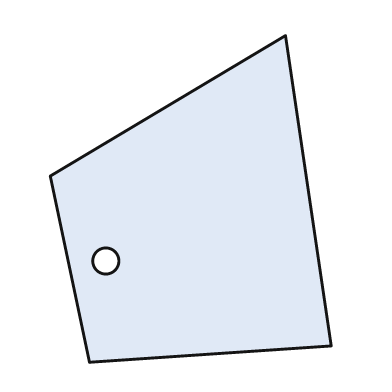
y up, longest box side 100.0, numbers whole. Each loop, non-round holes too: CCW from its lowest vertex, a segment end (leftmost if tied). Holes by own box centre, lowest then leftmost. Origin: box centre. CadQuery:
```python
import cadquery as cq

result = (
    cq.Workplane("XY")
    .moveTo(-31.0, -50.0)
    .lineTo(43.0, -45.0)
    .lineTo(29.0, 50.0)
    .lineTo(-43.0, 7.0)
    .close()
    .moveTo(-26.0, -19.0)
    .circle(4.0)
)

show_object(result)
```